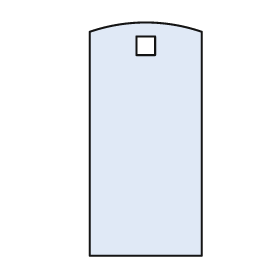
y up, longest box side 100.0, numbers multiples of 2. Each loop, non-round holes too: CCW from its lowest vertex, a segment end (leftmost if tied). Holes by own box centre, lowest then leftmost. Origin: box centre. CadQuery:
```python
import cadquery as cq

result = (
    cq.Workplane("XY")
    .moveTo(-24.0, -50.0)
    .lineTo(24.0, -50.0)
    .lineTo(24.0, 46.0)
    .threePointArc((0.0, 50.0), (-24.0, 46.0))
    .close()
    .moveTo(-4.0, 36.0)
    .lineTo(4.0, 36.0)
    .lineTo(4.0, 44.0)
    .lineTo(-4.0, 44.0)
    .close()
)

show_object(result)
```